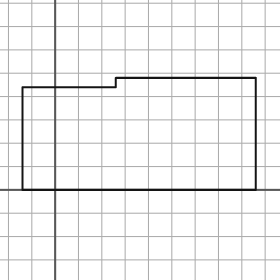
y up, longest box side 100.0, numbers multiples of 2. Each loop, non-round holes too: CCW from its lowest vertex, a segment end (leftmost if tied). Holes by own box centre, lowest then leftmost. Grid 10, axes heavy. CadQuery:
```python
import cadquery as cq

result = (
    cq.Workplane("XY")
    .moveTo(-14.0, 0.0)
    .lineTo(86.0, 0.0)
    .lineTo(86.0, 48.0)
    .lineTo(26.0, 48.0)
    .lineTo(26.0, 44.0)
    .lineTo(-14.0, 44.0)
    .close()
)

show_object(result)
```